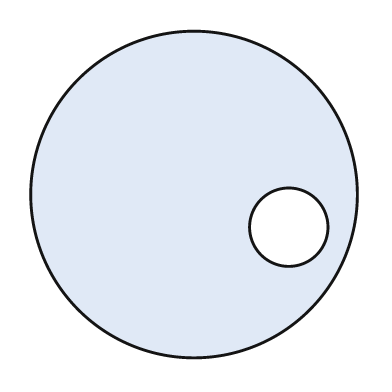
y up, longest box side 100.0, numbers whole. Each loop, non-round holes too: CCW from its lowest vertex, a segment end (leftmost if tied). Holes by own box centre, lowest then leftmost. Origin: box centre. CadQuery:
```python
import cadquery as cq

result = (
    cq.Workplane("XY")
    .moveTo(0.0, 0.0)
    .circle(50.0)
    .moveTo(29.0, -10.0)
    .circle(12.0)
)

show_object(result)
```